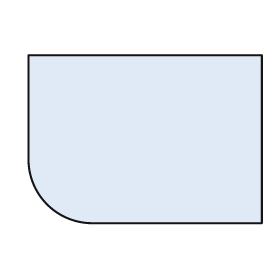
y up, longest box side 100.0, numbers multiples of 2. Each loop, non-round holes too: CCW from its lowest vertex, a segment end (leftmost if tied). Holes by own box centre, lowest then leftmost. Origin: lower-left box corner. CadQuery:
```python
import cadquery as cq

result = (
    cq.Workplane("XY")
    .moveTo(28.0, 0.0)
    .lineTo(100.0, 0.0)
    .lineTo(100.0, 72.0)
    .lineTo(0.0, 72.0)
    .lineTo(0.0, 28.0)
    .threePointArc((8.0, 8.0), (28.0, 0.0))
    .close()
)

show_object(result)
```